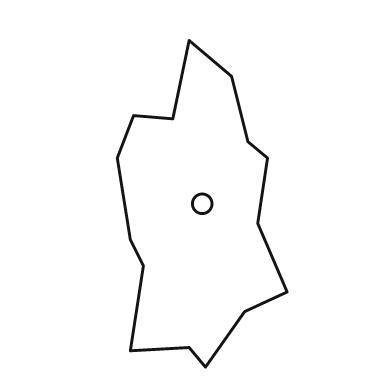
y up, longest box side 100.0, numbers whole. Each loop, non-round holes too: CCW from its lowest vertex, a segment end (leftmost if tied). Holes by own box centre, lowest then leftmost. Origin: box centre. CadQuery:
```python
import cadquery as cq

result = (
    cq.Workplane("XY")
    .moveTo(1.0, -50.0)
    .lineTo(13.0, -33.0)
    .lineTo(26.0, -27.0)
    .lineTo(17.0, -6.0)
    .lineTo(20.0, 14.0)
    .lineTo(14.0, 19.0)
    .lineTo(9.0, 39.0)
    .lineTo(-4.0, 50.0)
    .lineTo(-9.0, 26.0)
    .lineTo(-21.0, 27.0)
    .lineTo(-26.0, 14.0)
    .lineTo(-22.0, -11.0)
    .lineTo(-18.0, -19.0)
    .lineTo(-22.0, -45.0)
    .lineTo(-4.0, -44.0)
    .close()
    .moveTo(0.0, 0.0)
    .circle(3.0)
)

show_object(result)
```